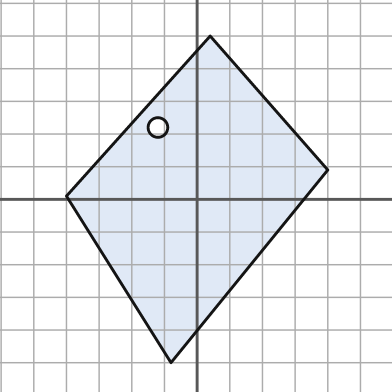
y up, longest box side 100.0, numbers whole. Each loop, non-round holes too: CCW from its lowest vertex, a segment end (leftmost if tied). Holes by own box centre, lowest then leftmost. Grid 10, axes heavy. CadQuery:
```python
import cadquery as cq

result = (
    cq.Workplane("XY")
    .moveTo(-8.0, -50.0)
    .lineTo(40.0, 9.0)
    .lineTo(4.0, 50.0)
    .lineTo(-40.0, 1.0)
    .close()
    .moveTo(-12.0, 22.0)
    .circle(3.0)
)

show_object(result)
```